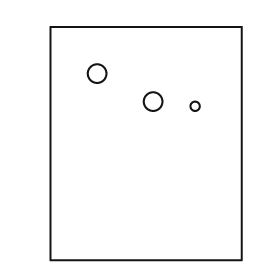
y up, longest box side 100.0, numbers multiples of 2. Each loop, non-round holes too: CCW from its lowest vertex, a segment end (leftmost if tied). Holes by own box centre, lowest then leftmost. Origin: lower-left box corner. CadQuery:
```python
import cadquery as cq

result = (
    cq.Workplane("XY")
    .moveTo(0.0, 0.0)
    .lineTo(82.0, 0.0)
    .lineTo(82.0, 100.0)
    .lineTo(0.0, 100.0)
    .close()
    .moveTo(62.0, 66.0)
    .circle(2.0)
    .moveTo(44.0, 68.0)
    .circle(4.0)
    .moveTo(20.0, 80.0)
    .circle(4.0)
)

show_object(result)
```